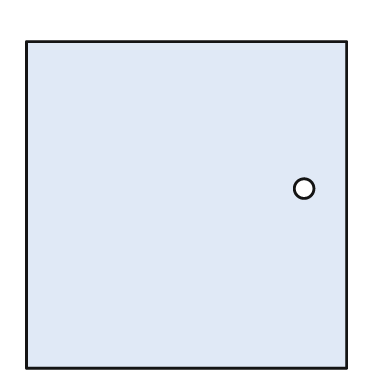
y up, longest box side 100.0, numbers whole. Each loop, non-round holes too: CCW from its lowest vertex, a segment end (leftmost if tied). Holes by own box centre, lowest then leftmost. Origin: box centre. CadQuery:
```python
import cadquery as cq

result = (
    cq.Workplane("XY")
    .moveTo(-49.0, -50.0)
    .lineTo(49.0, -50.0)
    .lineTo(49.0, 50.0)
    .lineTo(-49.0, 50.0)
    .close()
    .moveTo(36.0, 5.0)
    .circle(3.0)
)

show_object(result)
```